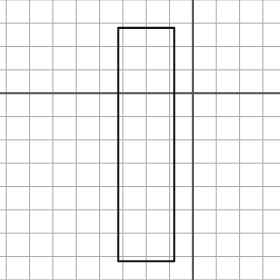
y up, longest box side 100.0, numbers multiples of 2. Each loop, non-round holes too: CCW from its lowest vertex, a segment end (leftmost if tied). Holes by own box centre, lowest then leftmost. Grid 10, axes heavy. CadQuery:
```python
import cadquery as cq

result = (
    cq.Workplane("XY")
    .moveTo(-32.0, -72.0)
    .lineTo(-8.0, -72.0)
    .lineTo(-8.0, 28.0)
    .lineTo(-32.0, 28.0)
    .close()
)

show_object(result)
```